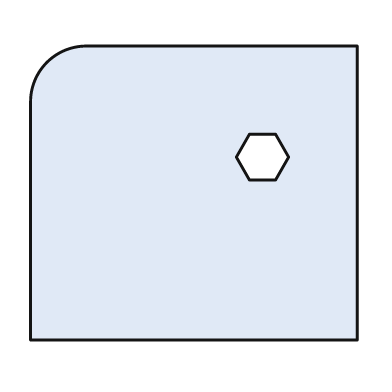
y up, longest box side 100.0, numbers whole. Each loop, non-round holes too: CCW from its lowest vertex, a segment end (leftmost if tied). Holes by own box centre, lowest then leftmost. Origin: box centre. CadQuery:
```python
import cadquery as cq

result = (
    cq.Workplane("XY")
    .moveTo(-50.0, -45.0)
    .lineTo(50.0, -45.0)
    .lineTo(50.0, 45.0)
    .lineTo(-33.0, 45.0)
    .threePointArc((-45.0, 40.0), (-50.0, 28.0))
    .close()
    .moveTo(17.0, 4.0)
    .lineTo(25.0, 4.0)
    .lineTo(29.0, 11.0)
    .lineTo(25.0, 18.0)
    .lineTo(17.0, 18.0)
    .lineTo(13.0, 11.0)
    .close()
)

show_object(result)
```